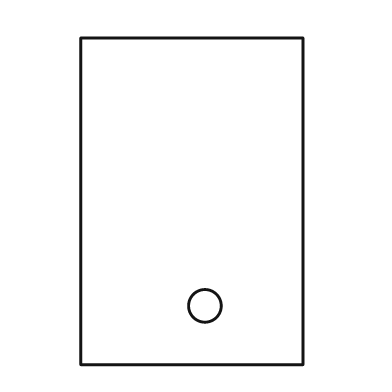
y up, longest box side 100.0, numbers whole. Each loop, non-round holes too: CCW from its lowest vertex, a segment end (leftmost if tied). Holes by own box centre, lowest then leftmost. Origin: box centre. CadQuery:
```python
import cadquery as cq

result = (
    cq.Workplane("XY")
    .moveTo(-34.0, -50.0)
    .lineTo(34.0, -50.0)
    .lineTo(34.0, 50.0)
    .lineTo(-34.0, 50.0)
    .close()
    .moveTo(4.0, -32.0)
    .circle(5.0)
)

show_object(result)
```